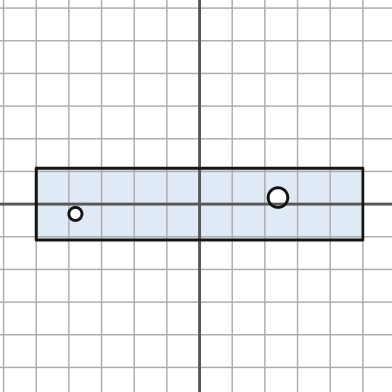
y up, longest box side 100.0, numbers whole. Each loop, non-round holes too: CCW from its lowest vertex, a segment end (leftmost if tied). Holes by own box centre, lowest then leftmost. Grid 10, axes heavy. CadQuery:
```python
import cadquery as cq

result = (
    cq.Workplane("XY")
    .moveTo(-50.0, -11.0)
    .lineTo(50.0, -11.0)
    .lineTo(50.0, 11.0)
    .lineTo(-50.0, 11.0)
    .close()
    .moveTo(-38.0, -3.0)
    .circle(2.0)
    .moveTo(24.0, 2.0)
    .circle(3.0)
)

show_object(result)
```